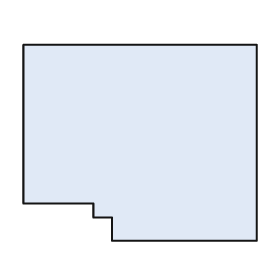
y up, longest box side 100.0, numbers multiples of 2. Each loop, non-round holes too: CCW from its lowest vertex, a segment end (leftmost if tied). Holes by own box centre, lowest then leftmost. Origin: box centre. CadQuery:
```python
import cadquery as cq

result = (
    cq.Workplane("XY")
    .moveTo(-12.0, -42.0)
    .lineTo(50.0, -42.0)
    .lineTo(50.0, 42.0)
    .lineTo(-50.0, 42.0)
    .lineTo(-50.0, -26.0)
    .lineTo(-20.0, -26.0)
    .lineTo(-20.0, -32.0)
    .lineTo(-12.0, -32.0)
    .close()
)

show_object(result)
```